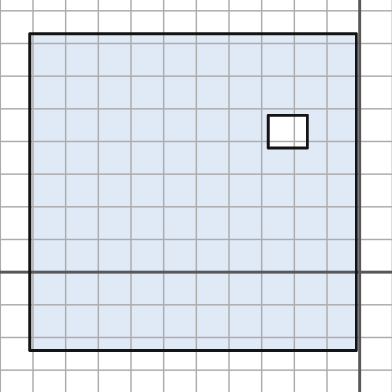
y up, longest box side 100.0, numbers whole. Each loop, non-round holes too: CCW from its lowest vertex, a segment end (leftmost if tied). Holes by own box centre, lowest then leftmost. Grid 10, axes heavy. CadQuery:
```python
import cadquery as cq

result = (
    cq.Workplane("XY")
    .moveTo(-101.0, -24.0)
    .lineTo(-1.0, -24.0)
    .lineTo(-1.0, 73.0)
    .lineTo(-101.0, 73.0)
    .close()
    .moveTo(-28.0, 38.0)
    .lineTo(-16.0, 38.0)
    .lineTo(-16.0, 48.0)
    .lineTo(-28.0, 48.0)
    .close()
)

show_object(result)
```